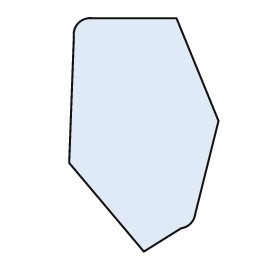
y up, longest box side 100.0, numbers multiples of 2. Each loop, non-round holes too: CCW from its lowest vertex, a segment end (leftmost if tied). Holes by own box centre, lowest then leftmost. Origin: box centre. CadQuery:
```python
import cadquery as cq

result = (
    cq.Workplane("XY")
    .moveTo(0.0, -50.0)
    .lineTo(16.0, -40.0)
    .threePointArc((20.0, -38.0), (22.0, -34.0))
    .lineTo(32.0, 6.0)
    .lineTo(14.0, 50.0)
    .lineTo(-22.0, 50.0)
    .threePointArc((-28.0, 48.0), (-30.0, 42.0))
    .lineTo(-32.0, -12.0)
    .close()
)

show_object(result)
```